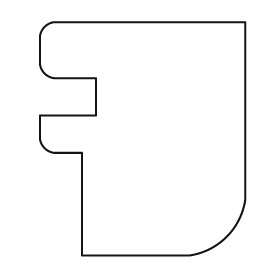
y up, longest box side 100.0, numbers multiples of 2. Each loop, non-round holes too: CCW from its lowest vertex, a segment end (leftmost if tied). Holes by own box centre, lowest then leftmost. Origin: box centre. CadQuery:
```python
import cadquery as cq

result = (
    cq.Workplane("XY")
    .moveTo(-26.0, -50.0)
    .lineTo(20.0, -50.0)
    .threePointArc((36.0, -42.0), (44.0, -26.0))
    .lineTo(44.0, 50.0)
    .lineTo(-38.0, 50.0)
    .threePointArc((-42.0, 48.0), (-44.0, 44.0))
    .lineTo(-44.0, 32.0)
    .threePointArc((-42.0, 28.0), (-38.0, 26.0))
    .lineTo(-20.0, 26.0)
    .lineTo(-20.0, 10.0)
    .lineTo(-44.0, 10.0)
    .lineTo(-44.0, 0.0)
    .threePointArc((-42.0, -4.0), (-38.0, -6.0))
    .lineTo(-26.0, -6.0)
    .close()
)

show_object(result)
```